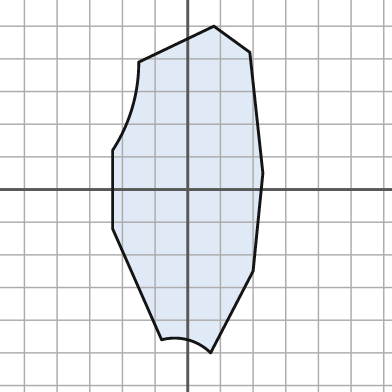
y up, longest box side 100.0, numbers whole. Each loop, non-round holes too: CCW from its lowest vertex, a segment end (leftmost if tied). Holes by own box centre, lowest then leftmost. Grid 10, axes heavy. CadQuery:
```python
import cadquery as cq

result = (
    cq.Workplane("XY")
    .moveTo(7.0, -50.0)
    .lineTo(20.0, -25.0)
    .lineTo(23.0, 5.0)
    .lineTo(19.0, 42.0)
    .lineTo(8.0, 50.0)
    .lineTo(-15.0, 39.0)
    .threePointArc((-17.0, 25.0), (-23.0, 12.0))
    .lineTo(-23.0, -12.0)
    .lineTo(-8.0, -46.0)
    .threePointArc((0.0, -46.0), (7.0, -50.0))
    .close()
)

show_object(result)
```